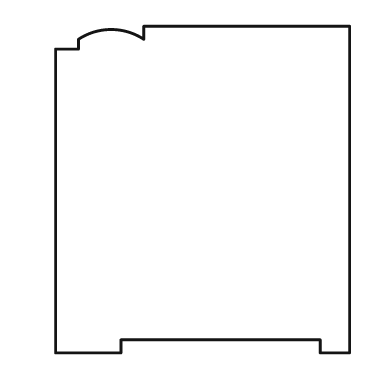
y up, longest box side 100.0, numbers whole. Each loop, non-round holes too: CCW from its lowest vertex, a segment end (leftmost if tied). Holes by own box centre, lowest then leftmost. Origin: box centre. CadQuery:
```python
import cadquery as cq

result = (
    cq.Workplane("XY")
    .moveTo(-45.0, -50.0)
    .lineTo(-25.0, -50.0)
    .lineTo(-25.0, -46.0)
    .lineTo(36.0, -46.0)
    .lineTo(36.0, -50.0)
    .lineTo(45.0, -50.0)
    .lineTo(45.0, 50.0)
    .lineTo(-18.0, 50.0)
    .lineTo(-18.0, 46.0)
    .threePointArc((-28.0, 49.0), (-38.0, 46.0))
    .lineTo(-38.0, 43.0)
    .lineTo(-45.0, 43.0)
    .close()
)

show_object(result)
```